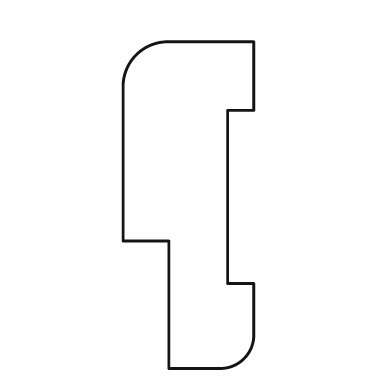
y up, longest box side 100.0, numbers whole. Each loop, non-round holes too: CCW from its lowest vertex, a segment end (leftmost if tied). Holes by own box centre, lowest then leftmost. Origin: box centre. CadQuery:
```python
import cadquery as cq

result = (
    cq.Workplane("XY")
    .moveTo(-6.0, -50.0)
    .lineTo(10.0, -50.0)
    .threePointArc((17.0, -47.0), (20.0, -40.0))
    .lineTo(20.0, -24.0)
    .lineTo(12.0, -24.0)
    .lineTo(12.0, 29.0)
    .lineTo(20.0, 29.0)
    .lineTo(20.0, 50.0)
    .lineTo(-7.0, 50.0)
    .threePointArc((-16.0, 46.0), (-20.0, 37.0))
    .lineTo(-20.0, -11.0)
    .lineTo(-6.0, -11.0)
    .close()
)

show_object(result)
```